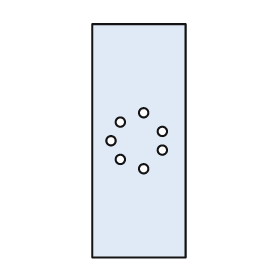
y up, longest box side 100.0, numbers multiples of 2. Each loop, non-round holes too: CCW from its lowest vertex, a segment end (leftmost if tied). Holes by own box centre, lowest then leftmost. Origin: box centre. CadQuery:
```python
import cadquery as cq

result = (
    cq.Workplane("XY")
    .moveTo(-20.0, -50.0)
    .lineTo(20.0, -50.0)
    .lineTo(20.0, 50.0)
    .lineTo(-20.0, 50.0)
    .close()
    .moveTo(2.0, -12.0)
    .circle(2.0)
    .moveTo(-8.0, -8.0)
    .circle(2.0)
    .moveTo(10.0, -4.0)
    .circle(2.0)
    .moveTo(-12.0, 0.0)
    .circle(2.0)
    .moveTo(10.0, 4.0)
    .circle(2.0)
    .moveTo(-8.0, 8.0)
    .circle(2.0)
    .moveTo(2.0, 12.0)
    .circle(2.0)
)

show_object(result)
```